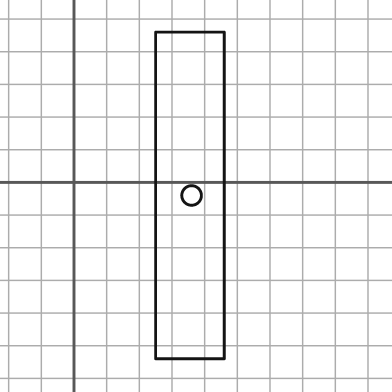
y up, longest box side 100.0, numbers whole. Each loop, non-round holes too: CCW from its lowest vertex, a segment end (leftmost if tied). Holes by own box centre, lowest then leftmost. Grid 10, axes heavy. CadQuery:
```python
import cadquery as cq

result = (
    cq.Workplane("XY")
    .moveTo(25.0, -54.0)
    .lineTo(46.0, -54.0)
    .lineTo(46.0, 46.0)
    .lineTo(25.0, 46.0)
    .close()
    .moveTo(36.0, -4.0)
    .circle(3.0)
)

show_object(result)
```